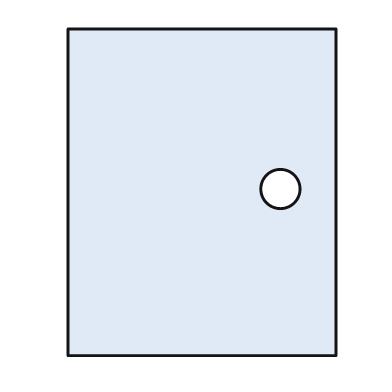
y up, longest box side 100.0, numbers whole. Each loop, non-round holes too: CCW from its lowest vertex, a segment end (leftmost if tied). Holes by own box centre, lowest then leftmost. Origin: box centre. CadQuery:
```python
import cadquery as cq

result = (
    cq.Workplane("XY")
    .moveTo(-41.0, -50.0)
    .lineTo(41.0, -50.0)
    .lineTo(41.0, 50.0)
    .lineTo(-41.0, 50.0)
    .close()
    .moveTo(24.0, 1.0)
    .circle(6.0)
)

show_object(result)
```